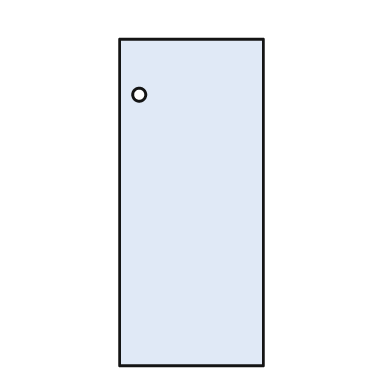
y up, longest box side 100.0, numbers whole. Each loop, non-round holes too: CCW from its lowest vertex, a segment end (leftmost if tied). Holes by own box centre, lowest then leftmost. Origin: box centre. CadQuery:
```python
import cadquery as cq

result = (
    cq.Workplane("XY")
    .moveTo(-22.0, -50.0)
    .lineTo(22.0, -50.0)
    .lineTo(22.0, 50.0)
    .lineTo(-22.0, 50.0)
    .close()
    .moveTo(-16.0, 33.0)
    .circle(2.0)
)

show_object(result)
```